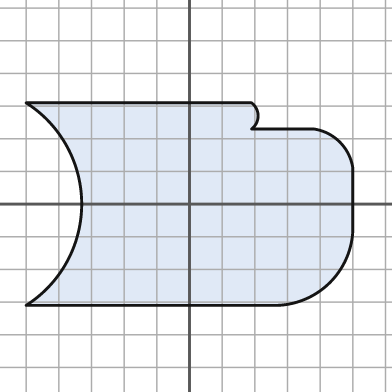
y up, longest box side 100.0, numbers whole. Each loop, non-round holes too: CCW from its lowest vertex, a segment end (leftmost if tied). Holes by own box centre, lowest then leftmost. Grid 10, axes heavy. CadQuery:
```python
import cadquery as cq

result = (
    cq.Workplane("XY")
    .moveTo(-50.0, -31.0)
    .lineTo(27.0, -31.0)
    .threePointArc((43.0, -24.0), (50.0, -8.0))
    .lineTo(50.0, 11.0)
    .threePointArc((46.0, 19.0), (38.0, 23.0))
    .lineTo(19.0, 23.0)
    .threePointArc((21.0, 27.0), (19.0, 31.0))
    .lineTo(-50.0, 31.0)
    .threePointArc((-33.0, 0.0), (-50.0, -31.0))
    .close()
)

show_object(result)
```